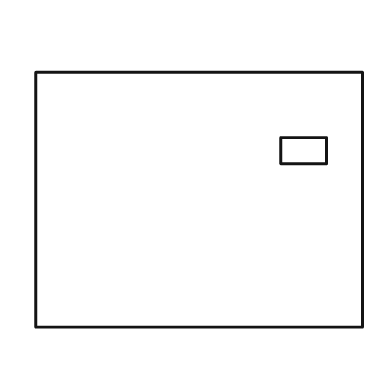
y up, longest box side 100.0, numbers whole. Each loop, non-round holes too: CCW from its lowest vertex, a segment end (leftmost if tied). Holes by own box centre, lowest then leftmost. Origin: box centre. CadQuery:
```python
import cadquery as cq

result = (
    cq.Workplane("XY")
    .moveTo(-50.0, -39.0)
    .lineTo(50.0, -39.0)
    .lineTo(50.0, 39.0)
    .lineTo(-50.0, 39.0)
    .close()
    .moveTo(25.0, 11.0)
    .lineTo(39.0, 11.0)
    .lineTo(39.0, 19.0)
    .lineTo(25.0, 19.0)
    .close()
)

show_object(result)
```